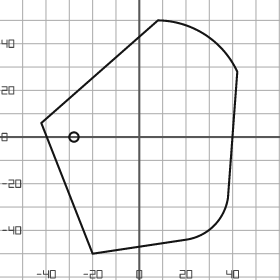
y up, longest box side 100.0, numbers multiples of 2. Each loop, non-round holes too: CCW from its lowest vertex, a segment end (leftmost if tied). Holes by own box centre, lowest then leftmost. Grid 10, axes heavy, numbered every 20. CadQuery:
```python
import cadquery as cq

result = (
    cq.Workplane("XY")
    .moveTo(-20.0, -50.0)
    .lineTo(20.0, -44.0)
    .threePointArc((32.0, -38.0), (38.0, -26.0))
    .lineTo(42.0, 28.0)
    .threePointArc((28.0, 44.0), (8.0, 50.0))
    .lineTo(-42.0, 6.0)
    .close()
    .moveTo(-28.0, 0.0)
    .circle(2.0)
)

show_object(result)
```